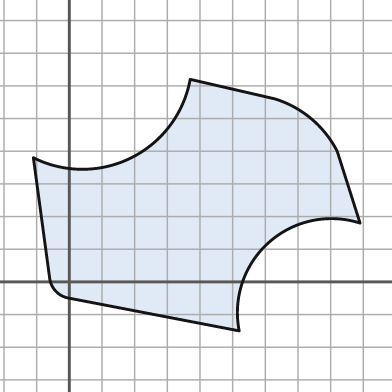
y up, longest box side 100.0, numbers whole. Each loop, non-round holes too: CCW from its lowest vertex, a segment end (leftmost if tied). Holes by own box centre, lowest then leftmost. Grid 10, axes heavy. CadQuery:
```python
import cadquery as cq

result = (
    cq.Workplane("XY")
    .moveTo(52.0, -15.0)
    .threePointArc((61.0, 12.0), (89.0, 18.0))
    .lineTo(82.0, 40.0)
    .threePointArc((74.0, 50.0), (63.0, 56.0))
    .lineTo(37.0, 62.0)
    .threePointArc((19.0, 38.0), (-11.0, 38.0))
    .lineTo(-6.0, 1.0)
    .threePointArc((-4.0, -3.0), (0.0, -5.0))
    .close()
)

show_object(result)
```